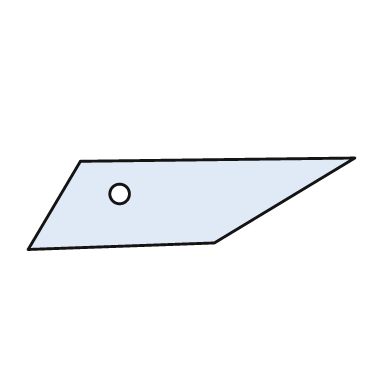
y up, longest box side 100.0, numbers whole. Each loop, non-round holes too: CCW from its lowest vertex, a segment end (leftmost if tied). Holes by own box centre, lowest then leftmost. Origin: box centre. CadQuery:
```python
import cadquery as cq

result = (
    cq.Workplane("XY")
    .moveTo(-50.0, -14.0)
    .lineTo(7.0, -12.0)
    .lineTo(50.0, 14.0)
    .lineTo(-34.0, 13.0)
    .close()
    .moveTo(-22.0, 3.0)
    .circle(3.0)
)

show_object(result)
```